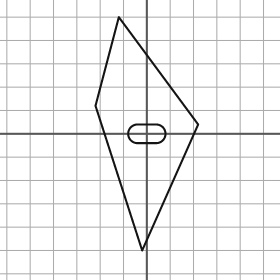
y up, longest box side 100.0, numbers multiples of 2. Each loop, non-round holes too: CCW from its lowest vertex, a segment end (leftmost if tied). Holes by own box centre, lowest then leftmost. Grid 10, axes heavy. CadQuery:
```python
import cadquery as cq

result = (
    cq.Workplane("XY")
    .moveTo(-2.0, -50.0)
    .lineTo(22.0, 4.0)
    .lineTo(-12.0, 50.0)
    .lineTo(-22.0, 12.0)
    .close()
    .moveTo(-4.0, -4.0)
    .lineTo(4.0, -4.0)
    .threePointArc((8.0, 0.0), (4.0, 4.0))
    .lineTo(-4.0, 4.0)
    .threePointArc((-8.0, 0.0), (-4.0, -4.0))
    .close()
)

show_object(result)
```